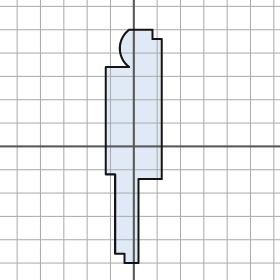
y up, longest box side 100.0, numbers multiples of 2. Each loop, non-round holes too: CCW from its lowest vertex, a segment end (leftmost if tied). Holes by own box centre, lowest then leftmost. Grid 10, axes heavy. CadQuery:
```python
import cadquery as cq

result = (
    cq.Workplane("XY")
    .moveTo(-4.0, -50.0)
    .lineTo(2.0, -50.0)
    .lineTo(2.0, -14.0)
    .lineTo(12.0, -14.0)
    .lineTo(12.0, 46.0)
    .lineTo(8.0, 46.0)
    .lineTo(8.0, 50.0)
    .lineTo(-2.0, 50.0)
    .threePointArc((-6.0, 42.0), (-2.0, 34.0))
    .lineTo(-12.0, 34.0)
    .lineTo(-12.0, -12.0)
    .lineTo(-8.0, -12.0)
    .lineTo(-8.0, -46.0)
    .lineTo(-4.0, -46.0)
    .close()
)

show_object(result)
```